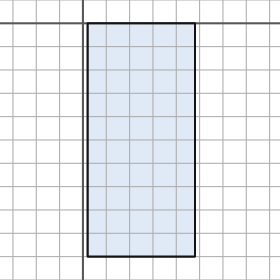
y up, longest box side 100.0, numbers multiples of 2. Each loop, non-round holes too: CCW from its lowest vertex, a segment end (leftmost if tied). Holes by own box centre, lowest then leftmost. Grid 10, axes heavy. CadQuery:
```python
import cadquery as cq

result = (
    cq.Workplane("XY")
    .moveTo(2.0, -100.0)
    .lineTo(48.0, -100.0)
    .lineTo(48.0, 0.0)
    .lineTo(2.0, 0.0)
    .close()
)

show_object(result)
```